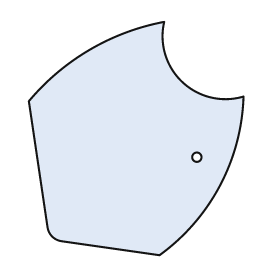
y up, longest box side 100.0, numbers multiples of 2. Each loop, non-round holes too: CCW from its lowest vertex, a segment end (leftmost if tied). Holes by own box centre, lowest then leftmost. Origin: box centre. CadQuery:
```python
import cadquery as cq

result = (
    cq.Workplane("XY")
    .moveTo(10.0, -50.0)
    .threePointArc((36.0, -20.0), (46.0, 18.0))
    .threePointArc((20.0, 24.0), (12.0, 50.0))
    .threePointArc((-20.0, 38.0), (-46.0, 16.0))
    .lineTo(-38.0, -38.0)
    .threePointArc((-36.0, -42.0), (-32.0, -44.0))
    .close()
    .moveTo(26.0, -8.0)
    .circle(2.0)
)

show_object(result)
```